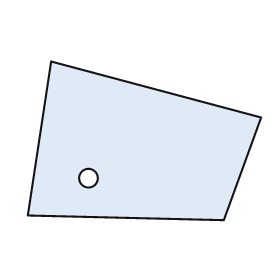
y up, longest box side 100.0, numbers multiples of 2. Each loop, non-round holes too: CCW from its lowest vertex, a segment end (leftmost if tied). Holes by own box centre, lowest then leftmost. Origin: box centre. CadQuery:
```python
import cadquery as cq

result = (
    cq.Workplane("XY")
    .moveTo(34.0, -34.0)
    .lineTo(50.0, 10.0)
    .lineTo(-40.0, 34.0)
    .lineTo(-50.0, -32.0)
    .close()
    .moveTo(-24.0, -16.0)
    .circle(4.0)
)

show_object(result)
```